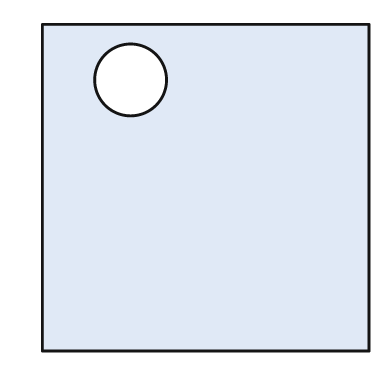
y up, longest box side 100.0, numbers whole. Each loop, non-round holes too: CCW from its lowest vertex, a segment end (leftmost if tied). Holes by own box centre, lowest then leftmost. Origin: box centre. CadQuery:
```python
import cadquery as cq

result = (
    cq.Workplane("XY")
    .moveTo(-50.0, -50.0)
    .lineTo(50.0, -50.0)
    .lineTo(50.0, 50.0)
    .lineTo(-50.0, 50.0)
    .close()
    .moveTo(-23.0, 33.0)
    .circle(11.0)
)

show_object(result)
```